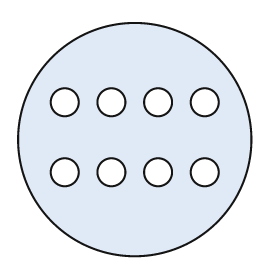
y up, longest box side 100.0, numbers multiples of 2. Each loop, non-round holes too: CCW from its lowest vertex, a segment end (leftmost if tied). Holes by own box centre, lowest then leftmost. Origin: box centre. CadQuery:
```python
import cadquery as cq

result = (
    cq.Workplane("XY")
    .moveTo(0.0, 0.0)
    .circle(50.0)
    .moveTo(-30.0, -14.0)
    .circle(6.0)
    .moveTo(-10.0, -14.0)
    .circle(6.0)
    .moveTo(10.0, -14.0)
    .circle(6.0)
    .moveTo(30.0, -14.0)
    .circle(6.0)
    .moveTo(-30.0, 16.0)
    .circle(6.0)
    .moveTo(-10.0, 16.0)
    .circle(6.0)
    .moveTo(10.0, 16.0)
    .circle(6.0)
    .moveTo(30.0, 16.0)
    .circle(6.0)
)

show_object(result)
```